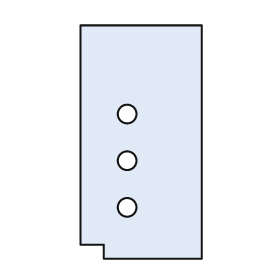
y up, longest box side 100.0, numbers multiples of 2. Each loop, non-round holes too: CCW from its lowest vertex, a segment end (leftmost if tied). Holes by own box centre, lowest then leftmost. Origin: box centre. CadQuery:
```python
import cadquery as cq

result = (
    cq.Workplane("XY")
    .moveTo(-16.0, -50.0)
    .lineTo(26.0, -50.0)
    .lineTo(26.0, 50.0)
    .lineTo(-26.0, 50.0)
    .lineTo(-26.0, -44.0)
    .lineTo(-16.0, -44.0)
    .close()
    .moveTo(-6.0, -28.0)
    .circle(4.0)
    .moveTo(-6.0, -8.0)
    .circle(4.0)
    .moveTo(-6.0, 12.0)
    .circle(4.0)
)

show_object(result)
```